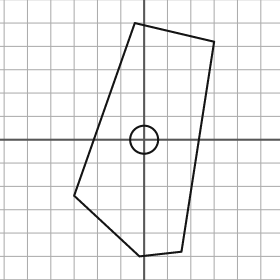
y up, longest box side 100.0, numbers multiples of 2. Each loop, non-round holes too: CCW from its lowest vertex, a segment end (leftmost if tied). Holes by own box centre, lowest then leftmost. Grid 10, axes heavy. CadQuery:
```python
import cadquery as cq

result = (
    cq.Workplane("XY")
    .moveTo(-2.0, -50.0)
    .lineTo(16.0, -48.0)
    .lineTo(30.0, 42.0)
    .lineTo(-4.0, 50.0)
    .lineTo(-30.0, -24.0)
    .close()
    .moveTo(0.0, 0.0)
    .circle(6.0)
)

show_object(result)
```